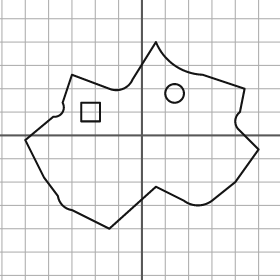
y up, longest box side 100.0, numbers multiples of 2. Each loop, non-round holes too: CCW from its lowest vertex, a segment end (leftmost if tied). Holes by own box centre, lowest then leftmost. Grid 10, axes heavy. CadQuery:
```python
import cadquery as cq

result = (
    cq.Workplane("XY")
    .moveTo(-14.0, -40.0)
    .lineTo(6.0, -22.0)
    .lineTo(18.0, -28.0)
    .threePointArc((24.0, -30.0), (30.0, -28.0))
    .lineTo(40.0, -20.0)
    .lineTo(50.0, -6.0)
    .lineTo(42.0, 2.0)
    .threePointArc((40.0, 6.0), (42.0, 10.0))
    .lineTo(44.0, 20.0)
    .lineTo(26.0, 26.0)
    .threePointArc((14.0, 30.0), (6.0, 40.0))
    .lineTo(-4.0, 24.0)
    .threePointArc((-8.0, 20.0), (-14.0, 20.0))
    .lineTo(-30.0, 26.0)
    .lineTo(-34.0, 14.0)
    .threePointArc((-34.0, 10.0), (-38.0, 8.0))
    .lineTo(-50.0, -2.0)
    .lineTo(-42.0, -18.0)
    .lineTo(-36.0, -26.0)
    .threePointArc((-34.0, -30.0), (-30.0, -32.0))
    .close()
    .moveTo(-26.0, 6.0)
    .lineTo(-18.0, 6.0)
    .lineTo(-18.0, 14.0)
    .lineTo(-26.0, 14.0)
    .close()
    .moveTo(14.0, 18.0)
    .circle(4.0)
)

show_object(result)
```